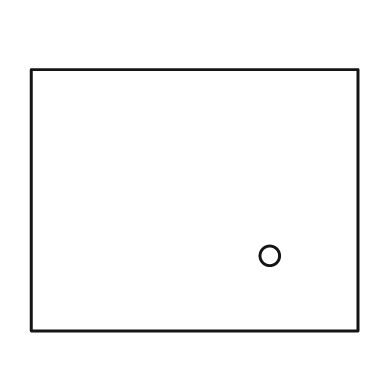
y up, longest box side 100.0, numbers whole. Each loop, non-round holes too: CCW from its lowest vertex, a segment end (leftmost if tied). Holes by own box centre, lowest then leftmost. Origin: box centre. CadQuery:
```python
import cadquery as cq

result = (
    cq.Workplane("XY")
    .moveTo(-50.0, -40.0)
    .lineTo(50.0, -40.0)
    .lineTo(50.0, 40.0)
    .lineTo(-50.0, 40.0)
    .close()
    .moveTo(23.0, -17.0)
    .circle(3.0)
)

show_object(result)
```